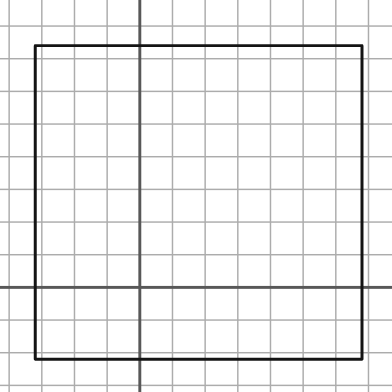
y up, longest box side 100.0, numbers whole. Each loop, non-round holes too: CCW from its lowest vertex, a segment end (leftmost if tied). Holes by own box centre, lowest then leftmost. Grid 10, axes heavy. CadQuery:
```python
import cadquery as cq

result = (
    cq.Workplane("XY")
    .moveTo(-32.0, -22.0)
    .lineTo(68.0, -22.0)
    .lineTo(68.0, 74.0)
    .lineTo(-32.0, 74.0)
    .close()
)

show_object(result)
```